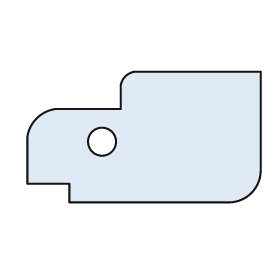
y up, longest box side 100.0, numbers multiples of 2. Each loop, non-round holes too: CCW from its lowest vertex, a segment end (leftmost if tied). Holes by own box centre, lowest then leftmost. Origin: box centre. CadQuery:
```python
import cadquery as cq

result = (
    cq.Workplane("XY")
    .moveTo(-32.0, -28.0)
    .lineTo(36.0, -28.0)
    .threePointArc((46.0, -24.0), (50.0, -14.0))
    .lineTo(50.0, 28.0)
    .lineTo(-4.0, 28.0)
    .threePointArc((-8.0, 26.0), (-10.0, 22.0))
    .lineTo(-10.0, 12.0)
    .lineTo(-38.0, 12.0)
    .threePointArc((-46.0, 8.0), (-50.0, 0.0))
    .lineTo(-50.0, -20.0)
    .lineTo(-32.0, -20.0)
    .close()
    .moveTo(-18.0, -2.0)
    .circle(6.0)
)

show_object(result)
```